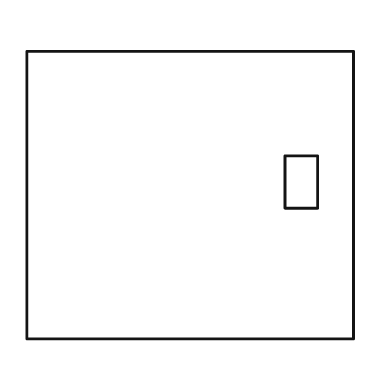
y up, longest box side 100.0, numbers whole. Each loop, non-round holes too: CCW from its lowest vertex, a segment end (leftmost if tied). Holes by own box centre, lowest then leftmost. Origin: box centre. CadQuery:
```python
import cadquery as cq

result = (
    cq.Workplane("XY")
    .moveTo(-50.0, -44.0)
    .lineTo(50.0, -44.0)
    .lineTo(50.0, 44.0)
    .lineTo(-50.0, 44.0)
    .close()
    .moveTo(29.0, -4.0)
    .lineTo(39.0, -4.0)
    .lineTo(39.0, 12.0)
    .lineTo(29.0, 12.0)
    .close()
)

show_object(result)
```